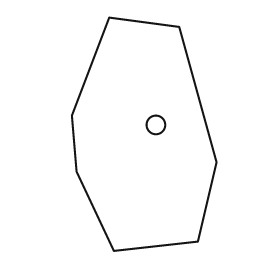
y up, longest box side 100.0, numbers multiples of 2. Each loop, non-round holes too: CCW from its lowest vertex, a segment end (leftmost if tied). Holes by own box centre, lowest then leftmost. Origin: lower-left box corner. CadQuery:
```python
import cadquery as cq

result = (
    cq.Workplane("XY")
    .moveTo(18.0, 0.0)
    .lineTo(54.0, 4.0)
    .lineTo(62.0, 38.0)
    .lineTo(46.0, 96.0)
    .lineTo(16.0, 100.0)
    .lineTo(0.0, 58.0)
    .lineTo(2.0, 34.0)
    .close()
    .moveTo(36.0, 54.0)
    .circle(4.0)
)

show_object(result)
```